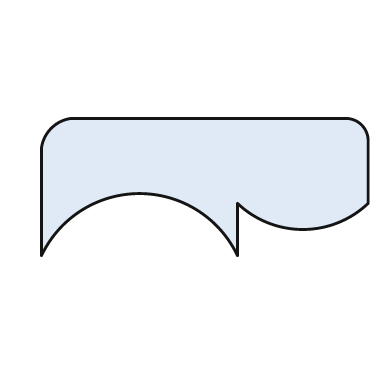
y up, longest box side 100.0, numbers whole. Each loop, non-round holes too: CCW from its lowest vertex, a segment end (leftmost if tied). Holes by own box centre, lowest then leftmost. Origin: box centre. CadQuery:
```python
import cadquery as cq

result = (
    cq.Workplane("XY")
    .moveTo(-50.0, -21.0)
    .threePointArc((-20.0, -2.0), (10.0, -21.0))
    .lineTo(10.0, -5.0)
    .threePointArc((30.0, -13.0), (50.0, -5.0))
    .lineTo(50.0, 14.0)
    .threePointArc((48.0, 19.0), (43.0, 21.0))
    .lineTo(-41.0, 21.0)
    .threePointArc((-47.0, 18.0), (-50.0, 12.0))
    .close()
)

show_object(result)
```